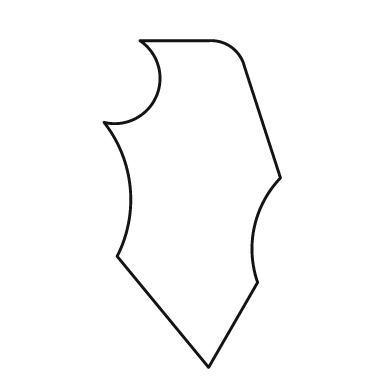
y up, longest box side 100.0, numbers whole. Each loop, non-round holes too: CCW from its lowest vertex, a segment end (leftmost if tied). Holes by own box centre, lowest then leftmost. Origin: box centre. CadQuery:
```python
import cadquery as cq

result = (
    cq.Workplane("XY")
    .moveTo(5.0, -50.0)
    .lineTo(20.0, -24.0)
    .threePointArc((19.0, -7.0), (27.0, 8.0))
    .lineTo(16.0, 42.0)
    .threePointArc((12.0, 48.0), (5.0, 50.0))
    .lineTo(-16.0, 50.0)
    .threePointArc((-11.0, 33.0), (-27.0, 25.0))
    .threePointArc((-19.0, 5.0), (-23.0, -16.0))
    .close()
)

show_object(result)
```